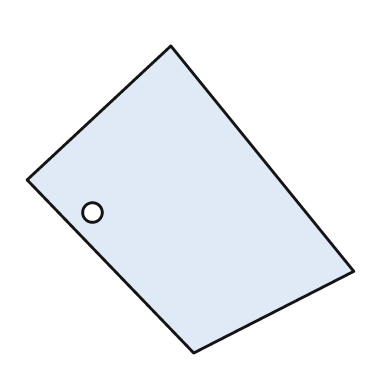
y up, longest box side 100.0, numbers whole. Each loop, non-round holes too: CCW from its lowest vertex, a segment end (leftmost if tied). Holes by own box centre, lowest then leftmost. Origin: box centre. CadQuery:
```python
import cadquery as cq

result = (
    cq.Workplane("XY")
    .moveTo(1.0, -47.0)
    .lineTo(50.0, -22.0)
    .lineTo(-6.0, 47.0)
    .lineTo(-50.0, 6.0)
    .close()
    .moveTo(-30.0, -4.0)
    .circle(3.0)
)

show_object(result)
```